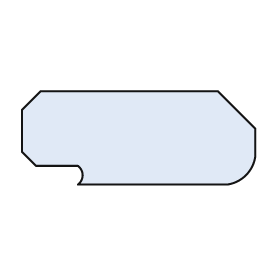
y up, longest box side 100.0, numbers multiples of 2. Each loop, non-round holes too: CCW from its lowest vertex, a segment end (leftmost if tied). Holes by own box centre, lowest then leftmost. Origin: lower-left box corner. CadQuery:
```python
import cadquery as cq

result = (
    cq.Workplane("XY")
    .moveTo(24.0, 0.0)
    .lineTo(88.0, 0.0)
    .threePointArc((96.0, 4.0), (100.0, 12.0))
    .lineTo(100.0, 24.0)
    .lineTo(84.0, 40.0)
    .lineTo(8.0, 40.0)
    .lineTo(0.0, 32.0)
    .lineTo(0.0, 14.0)
    .lineTo(6.0, 8.0)
    .lineTo(24.0, 8.0)
    .threePointArc((26.0, 4.0), (24.0, 0.0))
    .close()
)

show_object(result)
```